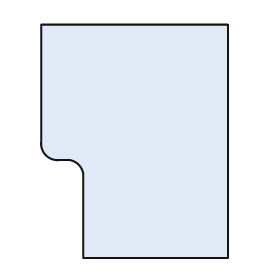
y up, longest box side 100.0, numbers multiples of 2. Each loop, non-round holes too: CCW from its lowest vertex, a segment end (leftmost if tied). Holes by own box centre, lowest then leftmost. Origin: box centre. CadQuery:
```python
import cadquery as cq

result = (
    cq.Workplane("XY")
    .moveTo(-22.0, -50.0)
    .lineTo(40.0, -50.0)
    .lineTo(40.0, 50.0)
    .lineTo(-40.0, 50.0)
    .lineTo(-40.0, 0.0)
    .threePointArc((-38.0, -6.0), (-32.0, -8.0))
    .lineTo(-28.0, -8.0)
    .threePointArc((-24.0, -10.0), (-22.0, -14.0))
    .close()
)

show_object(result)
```